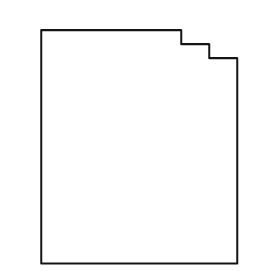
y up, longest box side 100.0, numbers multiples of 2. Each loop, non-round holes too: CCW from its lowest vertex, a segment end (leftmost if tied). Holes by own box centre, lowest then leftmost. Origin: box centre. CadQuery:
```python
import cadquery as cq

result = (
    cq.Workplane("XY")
    .moveTo(-42.0, -50.0)
    .lineTo(42.0, -50.0)
    .lineTo(42.0, 38.0)
    .lineTo(30.0, 38.0)
    .lineTo(30.0, 44.0)
    .lineTo(18.0, 44.0)
    .lineTo(18.0, 50.0)
    .lineTo(-42.0, 50.0)
    .close()
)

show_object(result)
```